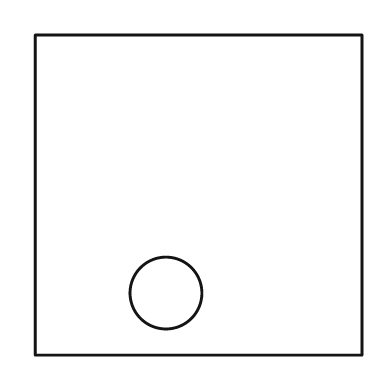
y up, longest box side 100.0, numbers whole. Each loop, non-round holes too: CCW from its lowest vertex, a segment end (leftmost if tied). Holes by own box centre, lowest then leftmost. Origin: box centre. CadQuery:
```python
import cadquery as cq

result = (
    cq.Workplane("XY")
    .moveTo(-50.0, -49.0)
    .lineTo(50.0, -49.0)
    .lineTo(50.0, 49.0)
    .lineTo(-50.0, 49.0)
    .close()
    .moveTo(-10.0, -30.0)
    .circle(11.0)
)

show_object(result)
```